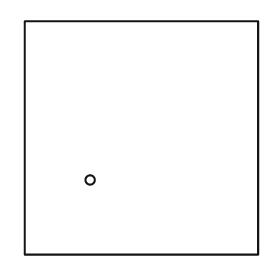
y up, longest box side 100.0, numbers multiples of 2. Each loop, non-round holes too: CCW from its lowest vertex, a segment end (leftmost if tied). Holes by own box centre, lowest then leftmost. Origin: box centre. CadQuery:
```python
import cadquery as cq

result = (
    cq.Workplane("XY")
    .moveTo(-50.0, -50.0)
    .lineTo(50.0, -50.0)
    .lineTo(50.0, 50.0)
    .lineTo(-50.0, 50.0)
    .close()
    .moveTo(-22.0, -18.0)
    .circle(2.0)
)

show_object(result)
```